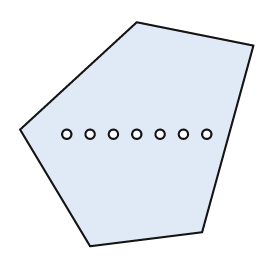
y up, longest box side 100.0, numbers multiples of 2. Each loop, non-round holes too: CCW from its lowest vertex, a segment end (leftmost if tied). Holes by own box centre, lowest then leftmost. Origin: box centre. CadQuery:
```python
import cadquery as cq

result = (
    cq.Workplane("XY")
    .moveTo(-20.0, -48.0)
    .lineTo(28.0, -42.0)
    .lineTo(50.0, 38.0)
    .lineTo(0.0, 48.0)
    .lineTo(-50.0, 2.0)
    .close()
    .moveTo(-30.0, 0.0)
    .circle(2.0)
    .moveTo(-20.0, 0.0)
    .circle(2.0)
    .moveTo(-10.0, 0.0)
    .circle(2.0)
    .moveTo(0.0, 0.0)
    .circle(2.0)
    .moveTo(10.0, 0.0)
    .circle(2.0)
    .moveTo(20.0, 0.0)
    .circle(2.0)
    .moveTo(30.0, 0.0)
    .circle(2.0)
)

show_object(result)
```